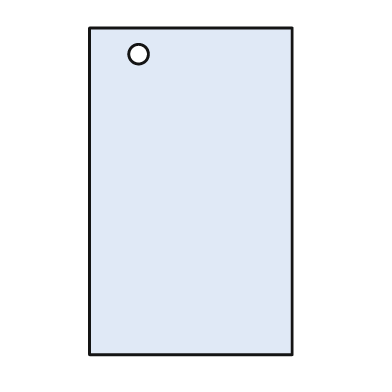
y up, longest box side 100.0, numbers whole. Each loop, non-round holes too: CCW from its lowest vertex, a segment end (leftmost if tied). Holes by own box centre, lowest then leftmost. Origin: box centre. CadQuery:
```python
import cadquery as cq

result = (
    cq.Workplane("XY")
    .moveTo(-31.0, -50.0)
    .lineTo(31.0, -50.0)
    .lineTo(31.0, 50.0)
    .lineTo(-31.0, 50.0)
    .close()
    .moveTo(-16.0, 42.0)
    .circle(3.0)
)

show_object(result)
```